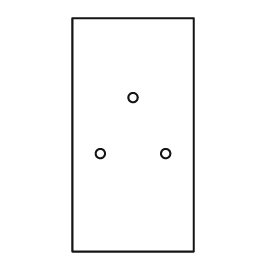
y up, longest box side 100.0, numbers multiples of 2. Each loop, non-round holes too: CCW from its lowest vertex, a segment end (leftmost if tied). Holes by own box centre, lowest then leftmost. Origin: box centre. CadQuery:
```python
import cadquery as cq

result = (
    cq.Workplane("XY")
    .moveTo(-26.0, -50.0)
    .lineTo(26.0, -50.0)
    .lineTo(26.0, 50.0)
    .lineTo(-26.0, 50.0)
    .close()
    .moveTo(-14.0, -8.0)
    .circle(2.0)
    .moveTo(14.0, -8.0)
    .circle(2.0)
    .moveTo(0.0, 16.0)
    .circle(2.0)
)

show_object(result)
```